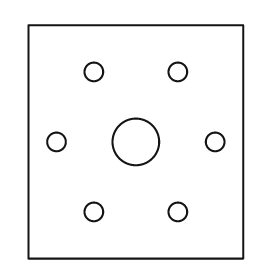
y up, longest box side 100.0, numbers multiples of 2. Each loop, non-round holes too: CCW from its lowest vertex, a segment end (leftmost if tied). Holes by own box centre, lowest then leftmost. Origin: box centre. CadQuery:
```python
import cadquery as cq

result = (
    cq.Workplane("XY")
    .moveTo(-46.0, -50.0)
    .lineTo(46.0, -50.0)
    .lineTo(46.0, 50.0)
    .lineTo(-46.0, 50.0)
    .close()
    .moveTo(-18.0, -30.0)
    .circle(4.0)
    .moveTo(18.0, -30.0)
    .circle(4.0)
    .moveTo(-34.0, 0.0)
    .circle(4.0)
    .moveTo(0.0, 0.0)
    .circle(10.0)
    .moveTo(34.0, 0.0)
    .circle(4.0)
    .moveTo(-18.0, 30.0)
    .circle(4.0)
    .moveTo(18.0, 30.0)
    .circle(4.0)
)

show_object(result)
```